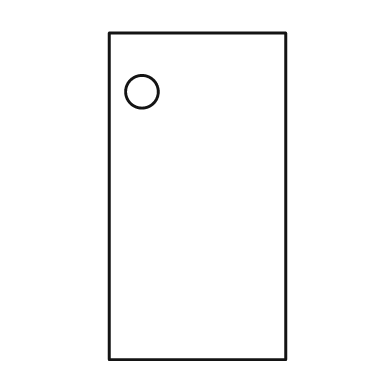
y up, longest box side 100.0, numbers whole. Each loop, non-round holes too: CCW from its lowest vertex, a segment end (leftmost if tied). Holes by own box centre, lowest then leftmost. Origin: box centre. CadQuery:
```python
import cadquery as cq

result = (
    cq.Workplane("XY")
    .moveTo(-27.0, -50.0)
    .lineTo(27.0, -50.0)
    .lineTo(27.0, 50.0)
    .lineTo(-27.0, 50.0)
    .close()
    .moveTo(-17.0, 32.0)
    .circle(5.0)
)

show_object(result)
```